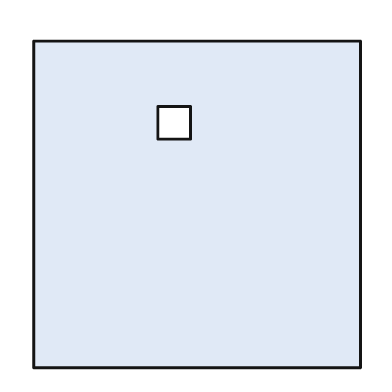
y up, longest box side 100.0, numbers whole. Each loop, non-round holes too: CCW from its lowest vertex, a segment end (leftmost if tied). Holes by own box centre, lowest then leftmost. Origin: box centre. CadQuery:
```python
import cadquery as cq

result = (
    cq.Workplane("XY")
    .moveTo(-50.0, -50.0)
    .lineTo(50.0, -50.0)
    .lineTo(50.0, 50.0)
    .lineTo(-50.0, 50.0)
    .close()
    .moveTo(-12.0, 20.0)
    .lineTo(-2.0, 20.0)
    .lineTo(-2.0, 30.0)
    .lineTo(-12.0, 30.0)
    .close()
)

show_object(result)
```